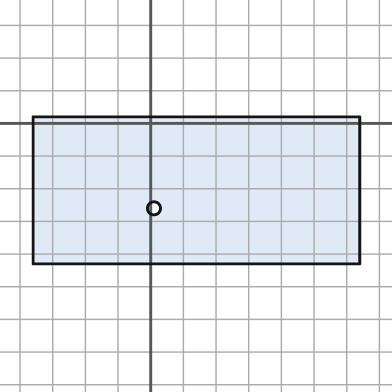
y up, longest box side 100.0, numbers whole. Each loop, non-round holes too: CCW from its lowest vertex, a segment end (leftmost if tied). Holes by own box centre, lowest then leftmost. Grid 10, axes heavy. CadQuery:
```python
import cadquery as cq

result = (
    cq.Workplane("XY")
    .moveTo(-36.0, -43.0)
    .lineTo(64.0, -43.0)
    .lineTo(64.0, 2.0)
    .lineTo(-36.0, 2.0)
    .close()
    .moveTo(1.0, -26.0)
    .circle(2.0)
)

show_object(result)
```